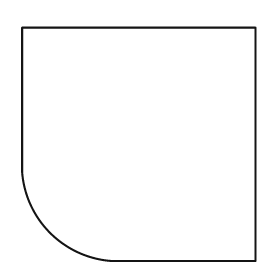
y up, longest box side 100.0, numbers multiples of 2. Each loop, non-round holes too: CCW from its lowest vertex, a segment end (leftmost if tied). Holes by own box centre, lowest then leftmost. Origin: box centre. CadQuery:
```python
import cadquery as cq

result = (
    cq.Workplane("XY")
    .moveTo(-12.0, -50.0)
    .lineTo(50.0, -50.0)
    .lineTo(50.0, 50.0)
    .lineTo(-50.0, 50.0)
    .lineTo(-50.0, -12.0)
    .threePointArc((-38.0, -38.0), (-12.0, -50.0))
    .close()
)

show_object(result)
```